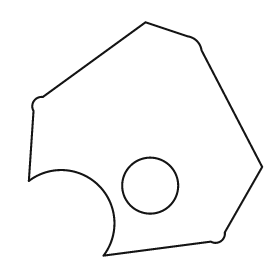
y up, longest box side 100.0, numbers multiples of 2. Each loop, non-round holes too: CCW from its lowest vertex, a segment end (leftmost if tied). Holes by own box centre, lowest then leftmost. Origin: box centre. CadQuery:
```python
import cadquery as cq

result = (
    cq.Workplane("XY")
    .moveTo(-18.0, -50.0)
    .lineTo(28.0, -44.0)
    .threePointArc((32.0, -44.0), (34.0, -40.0))
    .lineTo(50.0, -12.0)
    .lineTo(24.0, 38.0)
    .threePointArc((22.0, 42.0), (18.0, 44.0))
    .lineTo(0.0, 50.0)
    .lineTo(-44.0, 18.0)
    .threePointArc((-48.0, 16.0), (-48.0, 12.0))
    .lineTo(-50.0, -18.0)
    .threePointArc((-20.0, -20.0), (-18.0, -50.0))
    .close()
    .moveTo(2.0, -20.0)
    .circle(12.0)
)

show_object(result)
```